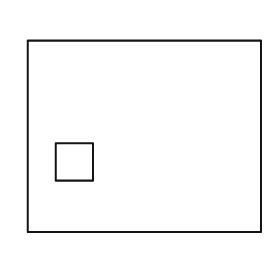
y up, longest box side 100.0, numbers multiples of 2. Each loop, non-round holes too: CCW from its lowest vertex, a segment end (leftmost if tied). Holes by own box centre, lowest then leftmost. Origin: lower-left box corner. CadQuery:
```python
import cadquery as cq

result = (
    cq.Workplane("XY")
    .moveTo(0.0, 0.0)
    .lineTo(100.0, 0.0)
    .lineTo(100.0, 82.0)
    .lineTo(0.0, 82.0)
    .close()
    .moveTo(12.0, 22.0)
    .lineTo(28.0, 22.0)
    .lineTo(28.0, 38.0)
    .lineTo(12.0, 38.0)
    .close()
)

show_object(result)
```